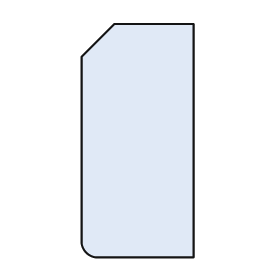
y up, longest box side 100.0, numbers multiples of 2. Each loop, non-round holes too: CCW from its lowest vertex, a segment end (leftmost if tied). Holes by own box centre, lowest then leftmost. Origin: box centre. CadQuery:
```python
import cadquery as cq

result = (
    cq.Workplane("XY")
    .moveTo(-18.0, -50.0)
    .lineTo(24.0, -50.0)
    .lineTo(24.0, 50.0)
    .lineTo(-10.0, 50.0)
    .lineTo(-24.0, 36.0)
    .lineTo(-24.0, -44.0)
    .threePointArc((-22.0, -48.0), (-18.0, -50.0))
    .close()
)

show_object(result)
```